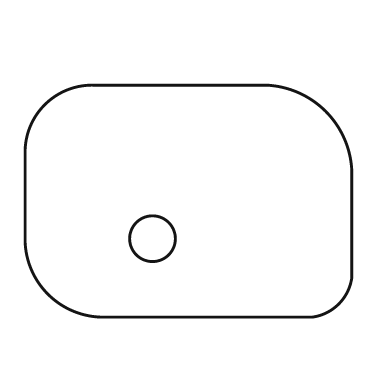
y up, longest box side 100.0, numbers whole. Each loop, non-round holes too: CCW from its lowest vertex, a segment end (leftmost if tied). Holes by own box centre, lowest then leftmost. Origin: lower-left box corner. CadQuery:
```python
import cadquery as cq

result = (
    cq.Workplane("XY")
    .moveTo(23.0, 0.0)
    .lineTo(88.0, 0.0)
    .threePointArc((96.0, 4.0), (100.0, 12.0))
    .lineTo(100.0, 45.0)
    .threePointArc((92.0, 63.0), (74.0, 71.0))
    .lineTo(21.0, 71.0)
    .threePointArc((6.0, 65.0), (0.0, 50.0))
    .lineTo(0.0, 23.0)
    .threePointArc((7.0, 7.0), (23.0, 0.0))
    .close()
    .moveTo(39.0, 24.0)
    .circle(7.0)
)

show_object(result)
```